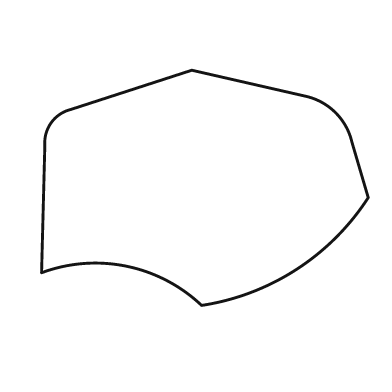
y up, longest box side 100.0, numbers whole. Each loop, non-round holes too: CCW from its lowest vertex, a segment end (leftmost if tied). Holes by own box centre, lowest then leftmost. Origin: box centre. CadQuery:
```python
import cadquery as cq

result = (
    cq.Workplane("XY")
    .moveTo(-1.0, -36.0)
    .threePointArc((28.0, -25.0), (50.0, -3.0))
    .lineTo(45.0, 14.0)
    .threePointArc((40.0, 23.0), (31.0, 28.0))
    .lineTo(-4.0, 36.0)
    .lineTo(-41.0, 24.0)
    .threePointArc((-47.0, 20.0), (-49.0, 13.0))
    .lineTo(-50.0, -26.0)
    .threePointArc((-24.0, -24.0), (-1.0, -36.0))
    .close()
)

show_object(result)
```